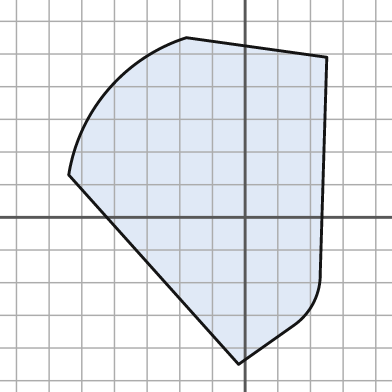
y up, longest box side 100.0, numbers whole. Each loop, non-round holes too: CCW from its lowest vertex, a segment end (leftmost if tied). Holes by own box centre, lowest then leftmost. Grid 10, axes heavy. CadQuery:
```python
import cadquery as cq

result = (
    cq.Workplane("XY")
    .moveTo(-2.0, -45.0)
    .lineTo(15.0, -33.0)
    .threePointArc((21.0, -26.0), (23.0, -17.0))
    .lineTo(25.0, 49.0)
    .lineTo(-18.0, 55.0)
    .threePointArc((-42.0, 39.0), (-54.0, 13.0))
    .close()
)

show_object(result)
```